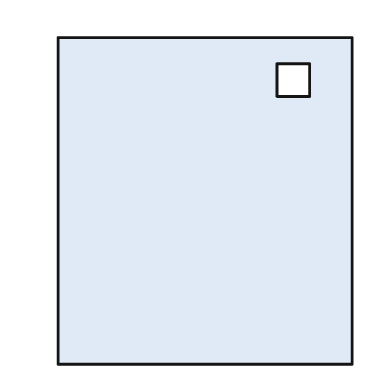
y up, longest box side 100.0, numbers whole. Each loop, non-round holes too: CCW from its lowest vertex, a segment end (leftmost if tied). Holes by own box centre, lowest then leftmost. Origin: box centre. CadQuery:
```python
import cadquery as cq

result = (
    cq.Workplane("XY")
    .moveTo(-45.0, -50.0)
    .lineTo(45.0, -50.0)
    .lineTo(45.0, 50.0)
    .lineTo(-45.0, 50.0)
    .close()
    .moveTo(22.0, 32.0)
    .lineTo(32.0, 32.0)
    .lineTo(32.0, 42.0)
    .lineTo(22.0, 42.0)
    .close()
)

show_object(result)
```